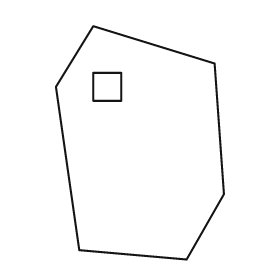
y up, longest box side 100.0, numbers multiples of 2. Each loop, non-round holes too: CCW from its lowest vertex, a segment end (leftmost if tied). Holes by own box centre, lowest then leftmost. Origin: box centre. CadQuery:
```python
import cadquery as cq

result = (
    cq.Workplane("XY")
    .moveTo(20.0, -50.0)
    .lineTo(36.0, -22.0)
    .lineTo(32.0, 34.0)
    .lineTo(-20.0, 50.0)
    .lineTo(-36.0, 24.0)
    .lineTo(-26.0, -46.0)
    .close()
    .moveTo(-20.0, 18.0)
    .lineTo(-8.0, 18.0)
    .lineTo(-8.0, 30.0)
    .lineTo(-20.0, 30.0)
    .close()
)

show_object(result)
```